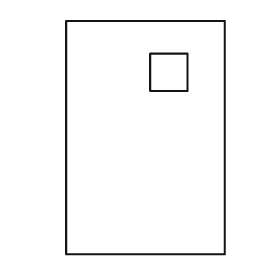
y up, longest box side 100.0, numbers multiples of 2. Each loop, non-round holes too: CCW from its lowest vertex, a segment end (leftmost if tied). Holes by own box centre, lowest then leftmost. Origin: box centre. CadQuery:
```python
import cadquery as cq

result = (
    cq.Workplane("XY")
    .moveTo(-34.0, -50.0)
    .lineTo(34.0, -50.0)
    .lineTo(34.0, 50.0)
    .lineTo(-34.0, 50.0)
    .close()
    .moveTo(2.0, 20.0)
    .lineTo(18.0, 20.0)
    .lineTo(18.0, 36.0)
    .lineTo(2.0, 36.0)
    .close()
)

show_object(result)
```